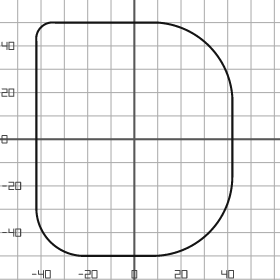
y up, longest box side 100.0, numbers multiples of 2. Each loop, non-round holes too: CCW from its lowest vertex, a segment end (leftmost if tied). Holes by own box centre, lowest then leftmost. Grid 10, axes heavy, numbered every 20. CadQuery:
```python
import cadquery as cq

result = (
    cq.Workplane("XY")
    .moveTo(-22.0, -50.0)
    .lineTo(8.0, -50.0)
    .threePointArc((32.0, -40.0), (42.0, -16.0))
    .lineTo(42.0, 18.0)
    .threePointArc((32.0, 40.0), (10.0, 50.0))
    .lineTo(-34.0, 50.0)
    .threePointArc((-40.0, 48.0), (-42.0, 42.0))
    .lineTo(-42.0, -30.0)
    .threePointArc((-36.0, -44.0), (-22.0, -50.0))
    .close()
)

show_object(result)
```